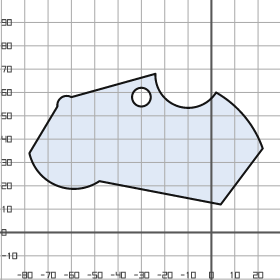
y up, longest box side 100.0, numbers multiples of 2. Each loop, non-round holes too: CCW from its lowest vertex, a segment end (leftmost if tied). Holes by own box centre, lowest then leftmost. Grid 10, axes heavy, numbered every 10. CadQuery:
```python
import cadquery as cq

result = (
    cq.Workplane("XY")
    .moveTo(4.0, 12.0)
    .lineTo(22.0, 36.0)
    .threePointArc((14.0, 50.0), (2.0, 60.0))
    .threePointArc((-14.0, 54.0), (-24.0, 68.0))
    .lineTo(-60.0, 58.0)
    .threePointArc((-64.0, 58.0), (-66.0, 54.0))
    .lineTo(-78.0, 34.0)
    .threePointArc((-66.0, 20.0), (-48.0, 22.0))
    .close()
    .moveTo(-30.0, 58.0)
    .circle(4.0)
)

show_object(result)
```